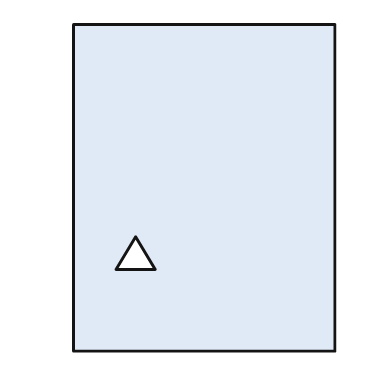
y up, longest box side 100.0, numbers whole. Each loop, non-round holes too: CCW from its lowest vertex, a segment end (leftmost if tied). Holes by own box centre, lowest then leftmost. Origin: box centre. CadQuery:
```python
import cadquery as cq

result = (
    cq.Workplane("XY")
    .moveTo(-40.0, -50.0)
    .lineTo(40.0, -50.0)
    .lineTo(40.0, 50.0)
    .lineTo(-40.0, 50.0)
    .close()
    .moveTo(-27.0, -25.0)
    .lineTo(-15.0, -25.0)
    .lineTo(-21.0, -15.0)
    .close()
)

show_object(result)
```